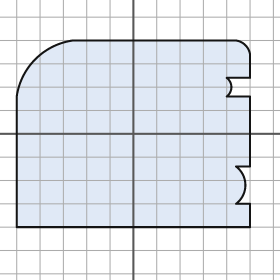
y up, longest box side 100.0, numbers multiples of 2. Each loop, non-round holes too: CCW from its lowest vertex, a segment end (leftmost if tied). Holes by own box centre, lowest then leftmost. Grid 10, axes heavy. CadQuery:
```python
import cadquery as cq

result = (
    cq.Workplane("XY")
    .moveTo(-50.0, -40.0)
    .lineTo(50.0, -40.0)
    .lineTo(50.0, -30.0)
    .lineTo(44.0, -30.0)
    .threePointArc((48.0, -22.0), (44.0, -14.0))
    .lineTo(50.0, -14.0)
    .lineTo(50.0, 16.0)
    .lineTo(40.0, 16.0)
    .threePointArc((42.0, 20.0), (40.0, 24.0))
    .lineTo(50.0, 24.0)
    .lineTo(50.0, 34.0)
    .threePointArc((48.0, 38.0), (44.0, 40.0))
    .lineTo(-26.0, 40.0)
    .threePointArc((-42.0, 32.0), (-50.0, 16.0))
    .close()
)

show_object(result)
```